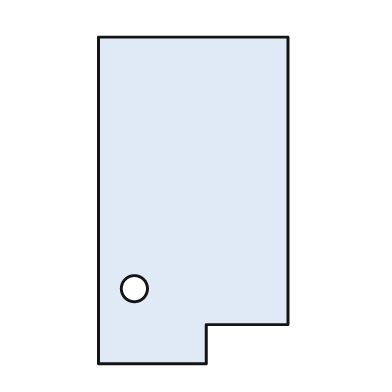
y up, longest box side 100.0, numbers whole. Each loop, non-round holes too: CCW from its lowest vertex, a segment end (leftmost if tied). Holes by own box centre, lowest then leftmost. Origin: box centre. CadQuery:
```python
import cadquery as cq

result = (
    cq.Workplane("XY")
    .moveTo(-29.0, -50.0)
    .lineTo(4.0, -50.0)
    .lineTo(4.0, -38.0)
    .lineTo(29.0, -38.0)
    .lineTo(29.0, 50.0)
    .lineTo(-29.0, 50.0)
    .close()
    .moveTo(-18.0, -27.0)
    .circle(4.0)
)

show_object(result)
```